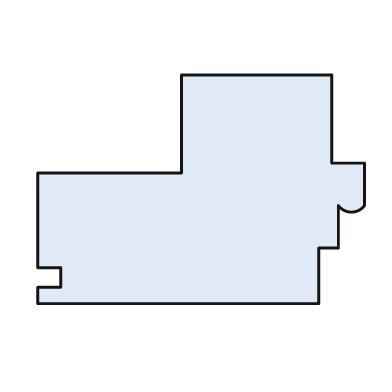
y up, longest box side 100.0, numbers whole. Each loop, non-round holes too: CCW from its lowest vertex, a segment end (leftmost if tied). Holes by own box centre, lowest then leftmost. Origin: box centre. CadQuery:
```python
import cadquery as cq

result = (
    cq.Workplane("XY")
    .moveTo(-50.0, -35.0)
    .lineTo(36.0, -35.0)
    .lineTo(36.0, -18.0)
    .lineTo(42.0, -18.0)
    .lineTo(42.0, -5.0)
    .threePointArc((46.0, -7.0), (50.0, -5.0))
    .lineTo(50.0, 8.0)
    .lineTo(40.0, 8.0)
    .lineTo(40.0, 35.0)
    .lineTo(-6.0, 35.0)
    .lineTo(-6.0, 5.0)
    .lineTo(-50.0, 5.0)
    .lineTo(-50.0, -24.0)
    .lineTo(-43.0, -24.0)
    .lineTo(-43.0, -30.0)
    .lineTo(-50.0, -30.0)
    .close()
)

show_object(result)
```